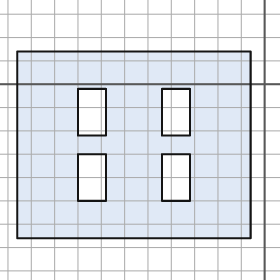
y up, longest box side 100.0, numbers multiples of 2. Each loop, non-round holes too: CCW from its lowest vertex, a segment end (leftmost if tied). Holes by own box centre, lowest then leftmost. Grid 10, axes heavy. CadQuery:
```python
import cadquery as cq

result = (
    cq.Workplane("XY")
    .moveTo(-106.0, -66.0)
    .lineTo(-6.0, -66.0)
    .lineTo(-6.0, 14.0)
    .lineTo(-106.0, 14.0)
    .close()
    .moveTo(-80.0, -50.0)
    .lineTo(-68.0, -50.0)
    .lineTo(-68.0, -30.0)
    .lineTo(-80.0, -30.0)
    .close()
    .moveTo(-44.0, -50.0)
    .lineTo(-32.0, -50.0)
    .lineTo(-32.0, -30.0)
    .lineTo(-44.0, -30.0)
    .close()
    .moveTo(-80.0, -22.0)
    .lineTo(-68.0, -22.0)
    .lineTo(-68.0, -2.0)
    .lineTo(-80.0, -2.0)
    .close()
    .moveTo(-44.0, -22.0)
    .lineTo(-32.0, -22.0)
    .lineTo(-32.0, -2.0)
    .lineTo(-44.0, -2.0)
    .close()
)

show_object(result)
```